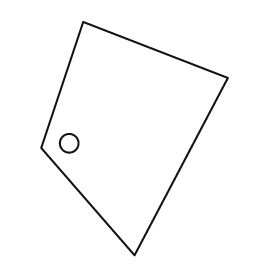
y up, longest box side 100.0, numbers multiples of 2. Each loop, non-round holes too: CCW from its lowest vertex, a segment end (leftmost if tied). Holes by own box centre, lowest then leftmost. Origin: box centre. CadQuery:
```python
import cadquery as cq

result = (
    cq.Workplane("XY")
    .moveTo(0.0, -50.0)
    .lineTo(40.0, 26.0)
    .lineTo(-22.0, 50.0)
    .lineTo(-40.0, -4.0)
    .close()
    .moveTo(-28.0, -2.0)
    .circle(4.0)
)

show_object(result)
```